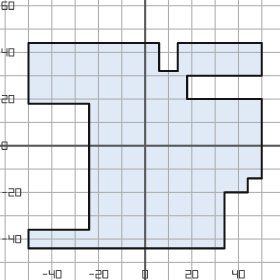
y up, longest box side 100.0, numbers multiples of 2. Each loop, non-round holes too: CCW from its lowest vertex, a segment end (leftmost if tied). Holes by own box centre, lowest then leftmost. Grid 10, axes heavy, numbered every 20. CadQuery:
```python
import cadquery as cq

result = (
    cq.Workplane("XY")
    .moveTo(-50.0, -44.0)
    .lineTo(34.0, -44.0)
    .lineTo(34.0, -20.0)
    .lineTo(44.0, -20.0)
    .lineTo(44.0, -14.0)
    .lineTo(50.0, -14.0)
    .lineTo(50.0, 20.0)
    .lineTo(18.0, 20.0)
    .lineTo(18.0, 30.0)
    .lineTo(50.0, 30.0)
    .lineTo(50.0, 44.0)
    .lineTo(14.0, 44.0)
    .lineTo(14.0, 32.0)
    .lineTo(6.0, 32.0)
    .lineTo(6.0, 44.0)
    .lineTo(-50.0, 44.0)
    .lineTo(-50.0, 18.0)
    .lineTo(-24.0, 18.0)
    .lineTo(-24.0, -36.0)
    .lineTo(-50.0, -36.0)
    .close()
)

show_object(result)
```